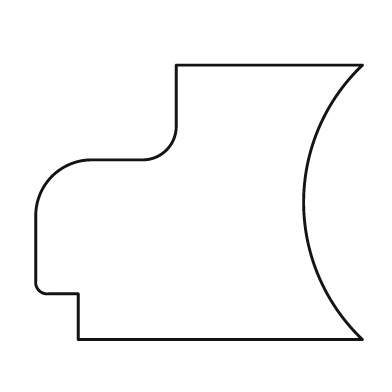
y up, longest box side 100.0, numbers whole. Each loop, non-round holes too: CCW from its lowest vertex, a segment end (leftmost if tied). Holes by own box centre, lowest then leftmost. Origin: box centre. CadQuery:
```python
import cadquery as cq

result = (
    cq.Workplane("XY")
    .moveTo(-37.0, -42.0)
    .lineTo(50.0, -42.0)
    .threePointArc((32.0, 0.0), (50.0, 42.0))
    .lineTo(-7.0, 42.0)
    .lineTo(-7.0, 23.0)
    .threePointArc((-10.0, 16.0), (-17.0, 13.0))
    .lineTo(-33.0, 13.0)
    .threePointArc((-45.0, 8.0), (-50.0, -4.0))
    .lineTo(-50.0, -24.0)
    .threePointArc((-49.0, -27.0), (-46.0, -28.0))
    .lineTo(-37.0, -28.0)
    .close()
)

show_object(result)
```